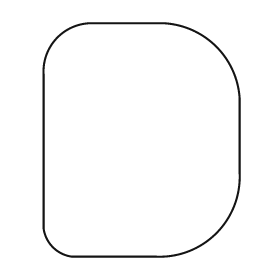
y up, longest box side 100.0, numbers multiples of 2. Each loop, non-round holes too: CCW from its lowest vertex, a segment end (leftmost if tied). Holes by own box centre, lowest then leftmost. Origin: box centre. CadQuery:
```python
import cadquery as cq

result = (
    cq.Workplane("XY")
    .moveTo(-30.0, -50.0)
    .lineTo(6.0, -50.0)
    .threePointArc((32.0, -40.0), (42.0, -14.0))
    .lineTo(42.0, 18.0)
    .threePointArc((32.0, 40.0), (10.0, 50.0))
    .lineTo(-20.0, 50.0)
    .threePointArc((-36.0, 44.0), (-42.0, 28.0))
    .lineTo(-42.0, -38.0)
    .threePointArc((-38.0, -46.0), (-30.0, -50.0))
    .close()
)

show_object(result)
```